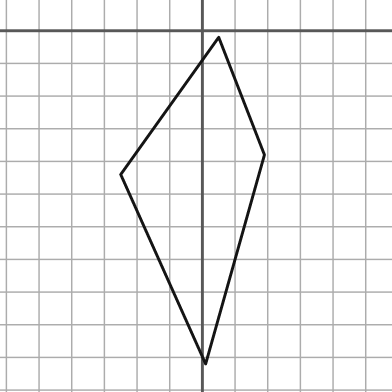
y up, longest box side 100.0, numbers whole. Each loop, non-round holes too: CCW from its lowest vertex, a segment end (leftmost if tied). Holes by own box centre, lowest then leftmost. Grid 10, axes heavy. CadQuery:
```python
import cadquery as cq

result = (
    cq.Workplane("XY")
    .moveTo(1.0, -102.0)
    .lineTo(19.0, -38.0)
    .lineTo(5.0, -2.0)
    .lineTo(-25.0, -44.0)
    .close()
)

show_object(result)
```